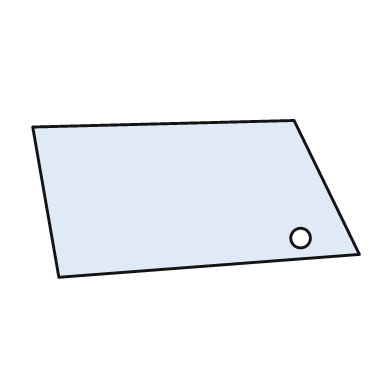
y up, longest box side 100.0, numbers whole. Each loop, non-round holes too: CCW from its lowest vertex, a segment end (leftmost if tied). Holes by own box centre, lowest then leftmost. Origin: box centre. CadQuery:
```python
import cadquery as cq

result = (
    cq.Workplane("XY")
    .moveTo(-42.0, -24.0)
    .lineTo(50.0, -17.0)
    .lineTo(30.0, 24.0)
    .lineTo(-50.0, 22.0)
    .close()
    .moveTo(32.0, -12.0)
    .circle(3.0)
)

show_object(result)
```